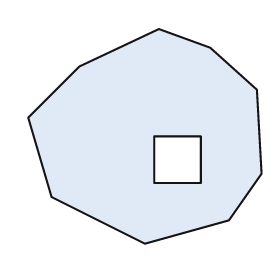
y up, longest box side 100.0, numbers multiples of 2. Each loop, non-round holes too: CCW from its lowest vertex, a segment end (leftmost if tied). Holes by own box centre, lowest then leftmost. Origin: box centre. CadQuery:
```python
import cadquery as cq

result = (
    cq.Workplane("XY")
    .moveTo(0.0, -46.0)
    .lineTo(36.0, -36.0)
    .lineTo(50.0, -16.0)
    .lineTo(48.0, 20.0)
    .lineTo(28.0, 38.0)
    .lineTo(6.0, 46.0)
    .lineTo(-28.0, 30.0)
    .lineTo(-50.0, 8.0)
    .lineTo(-40.0, -26.0)
    .close()
    .moveTo(4.0, -20.0)
    .lineTo(24.0, -20.0)
    .lineTo(24.0, 0.0)
    .lineTo(4.0, 0.0)
    .close()
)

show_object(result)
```